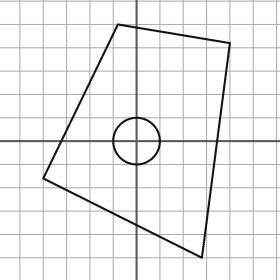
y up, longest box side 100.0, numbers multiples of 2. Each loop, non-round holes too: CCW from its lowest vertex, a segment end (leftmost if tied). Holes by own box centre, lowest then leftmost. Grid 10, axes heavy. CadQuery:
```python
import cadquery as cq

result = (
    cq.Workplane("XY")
    .moveTo(28.0, -50.0)
    .lineTo(40.0, 42.0)
    .lineTo(-8.0, 50.0)
    .lineTo(-40.0, -16.0)
    .close()
    .moveTo(0.0, 0.0)
    .circle(10.0)
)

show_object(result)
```